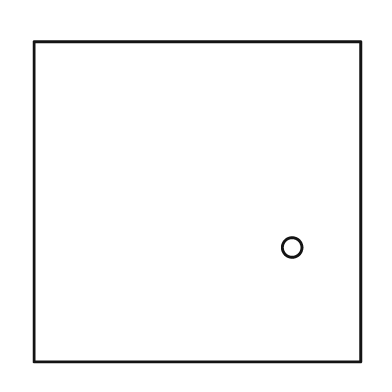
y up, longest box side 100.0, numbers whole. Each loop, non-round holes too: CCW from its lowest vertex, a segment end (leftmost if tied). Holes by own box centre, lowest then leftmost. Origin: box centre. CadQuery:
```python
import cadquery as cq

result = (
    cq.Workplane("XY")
    .moveTo(-50.0, -49.0)
    .lineTo(50.0, -49.0)
    .lineTo(50.0, 49.0)
    .lineTo(-50.0, 49.0)
    .close()
    .moveTo(29.0, -14.0)
    .circle(3.0)
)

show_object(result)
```